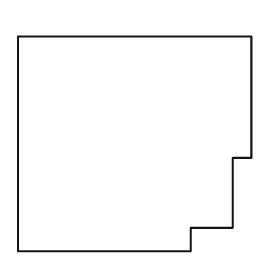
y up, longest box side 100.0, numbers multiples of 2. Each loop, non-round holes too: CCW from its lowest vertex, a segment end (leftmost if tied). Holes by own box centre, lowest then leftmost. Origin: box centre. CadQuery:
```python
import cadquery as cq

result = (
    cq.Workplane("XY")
    .moveTo(-50.0, -46.0)
    .lineTo(24.0, -46.0)
    .lineTo(24.0, -36.0)
    .lineTo(42.0, -36.0)
    .lineTo(42.0, -6.0)
    .lineTo(50.0, -6.0)
    .lineTo(50.0, 46.0)
    .lineTo(-50.0, 46.0)
    .close()
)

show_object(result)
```